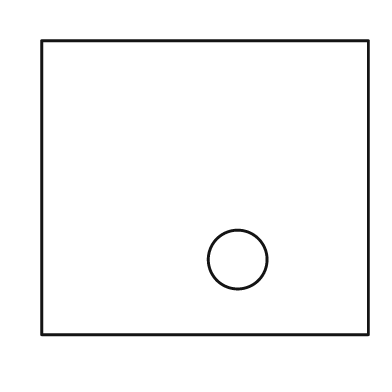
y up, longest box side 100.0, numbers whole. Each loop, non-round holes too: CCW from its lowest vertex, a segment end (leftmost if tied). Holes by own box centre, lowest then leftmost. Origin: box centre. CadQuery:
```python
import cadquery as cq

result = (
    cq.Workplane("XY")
    .moveTo(-50.0, -45.0)
    .lineTo(50.0, -45.0)
    .lineTo(50.0, 45.0)
    .lineTo(-50.0, 45.0)
    .close()
    .moveTo(10.0, -22.0)
    .circle(9.0)
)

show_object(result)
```